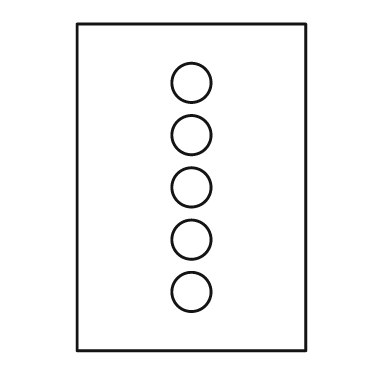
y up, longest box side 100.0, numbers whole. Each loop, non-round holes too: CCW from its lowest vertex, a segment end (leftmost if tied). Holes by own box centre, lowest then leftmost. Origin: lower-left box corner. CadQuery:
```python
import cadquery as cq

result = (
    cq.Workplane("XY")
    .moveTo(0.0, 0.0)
    .lineTo(70.0, 0.0)
    .lineTo(70.0, 100.0)
    .lineTo(0.0, 100.0)
    .close()
    .moveTo(35.0, 18.0)
    .circle(6.0)
    .moveTo(35.0, 34.0)
    .circle(6.0)
    .moveTo(35.0, 50.0)
    .circle(6.0)
    .moveTo(35.0, 66.0)
    .circle(6.0)
    .moveTo(35.0, 82.0)
    .circle(6.0)
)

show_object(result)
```